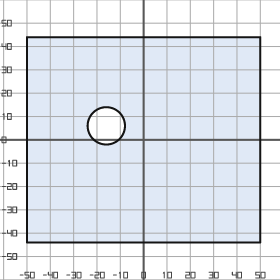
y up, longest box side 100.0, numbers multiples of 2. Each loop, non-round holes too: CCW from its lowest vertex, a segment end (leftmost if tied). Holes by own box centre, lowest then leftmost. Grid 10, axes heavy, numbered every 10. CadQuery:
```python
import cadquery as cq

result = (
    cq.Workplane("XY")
    .moveTo(-50.0, -44.0)
    .lineTo(50.0, -44.0)
    .lineTo(50.0, 44.0)
    .lineTo(-50.0, 44.0)
    .close()
    .moveTo(-16.0, 6.0)
    .circle(8.0)
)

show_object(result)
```